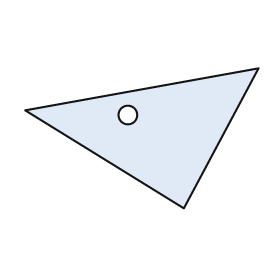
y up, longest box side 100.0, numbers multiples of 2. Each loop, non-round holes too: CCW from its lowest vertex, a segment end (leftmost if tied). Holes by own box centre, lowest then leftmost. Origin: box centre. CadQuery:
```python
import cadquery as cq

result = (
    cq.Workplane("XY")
    .moveTo(18.0, -30.0)
    .lineTo(50.0, 30.0)
    .lineTo(-50.0, 12.0)
    .close()
    .moveTo(-6.0, 10.0)
    .circle(4.0)
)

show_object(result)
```